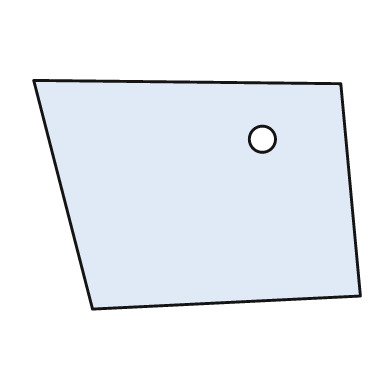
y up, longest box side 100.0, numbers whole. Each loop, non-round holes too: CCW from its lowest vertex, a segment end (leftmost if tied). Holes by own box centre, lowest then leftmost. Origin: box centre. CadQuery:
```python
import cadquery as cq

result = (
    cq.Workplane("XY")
    .moveTo(-32.0, -35.0)
    .lineTo(50.0, -31.0)
    .lineTo(44.0, 34.0)
    .lineTo(-50.0, 35.0)
    .close()
    .moveTo(20.0, 17.0)
    .circle(4.0)
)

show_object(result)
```